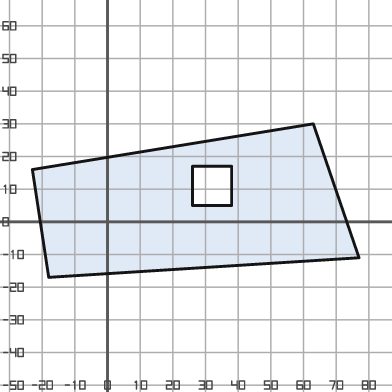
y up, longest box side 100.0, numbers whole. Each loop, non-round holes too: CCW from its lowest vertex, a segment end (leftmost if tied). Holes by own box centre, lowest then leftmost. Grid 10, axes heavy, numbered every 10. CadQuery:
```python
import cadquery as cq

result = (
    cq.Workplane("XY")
    .moveTo(-18.0, -17.0)
    .lineTo(77.0, -11.0)
    .lineTo(63.0, 30.0)
    .lineTo(-23.0, 16.0)
    .close()
    .moveTo(26.0, 5.0)
    .lineTo(38.0, 5.0)
    .lineTo(38.0, 17.0)
    .lineTo(26.0, 17.0)
    .close()
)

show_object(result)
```